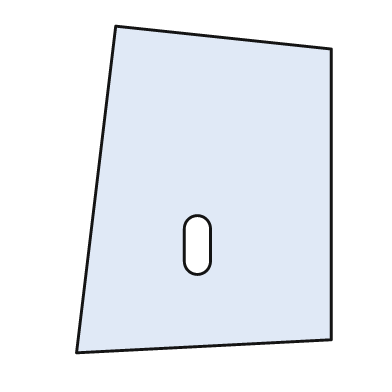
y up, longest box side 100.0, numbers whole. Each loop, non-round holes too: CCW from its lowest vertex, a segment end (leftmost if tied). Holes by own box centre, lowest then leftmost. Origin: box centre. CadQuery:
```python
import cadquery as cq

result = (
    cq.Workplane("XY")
    .moveTo(-39.0, -50.0)
    .lineTo(39.0, -46.0)
    .lineTo(39.0, 43.0)
    .lineTo(-27.0, 50.0)
    .close()
    .moveTo(-6.0, -22.0)
    .threePointArc((-2.0, -26.0), (2.0, -22.0))
    .lineTo(2.0, -12.0)
    .threePointArc((-2.0, -8.0), (-6.0, -12.0))
    .close()
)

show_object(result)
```